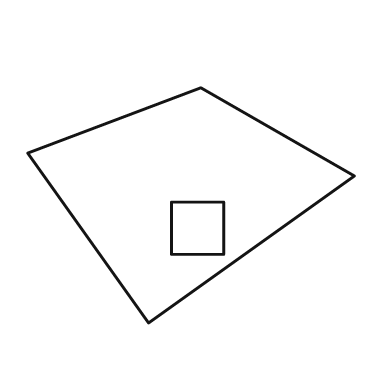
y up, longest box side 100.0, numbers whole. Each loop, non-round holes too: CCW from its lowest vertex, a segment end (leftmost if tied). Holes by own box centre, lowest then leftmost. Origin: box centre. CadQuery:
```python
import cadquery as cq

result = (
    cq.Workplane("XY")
    .moveTo(-13.0, -36.0)
    .lineTo(50.0, 9.0)
    .lineTo(3.0, 36.0)
    .lineTo(-50.0, 16.0)
    .close()
    .moveTo(-6.0, -15.0)
    .lineTo(10.0, -15.0)
    .lineTo(10.0, 1.0)
    .lineTo(-6.0, 1.0)
    .close()
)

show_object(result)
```